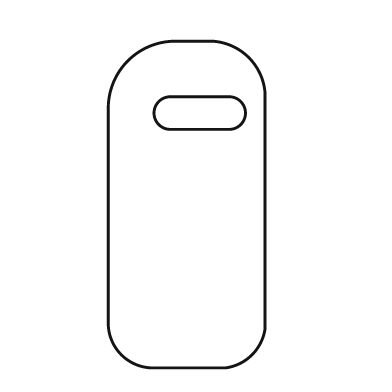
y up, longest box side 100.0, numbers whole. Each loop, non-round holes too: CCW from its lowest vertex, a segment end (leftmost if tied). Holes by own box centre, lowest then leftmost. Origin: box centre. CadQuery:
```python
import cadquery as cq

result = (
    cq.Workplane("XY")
    .moveTo(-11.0, -50.0)
    .lineTo(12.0, -50.0)
    .threePointArc((20.0, -46.0), (24.0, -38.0))
    .lineTo(24.0, 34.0)
    .threePointArc((19.0, 45.0), (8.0, 50.0))
    .lineTo(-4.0, 50.0)
    .threePointArc((-18.0, 44.0), (-24.0, 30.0))
    .lineTo(-24.0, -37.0)
    .threePointArc((-20.0, -46.0), (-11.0, -50.0))
    .close()
    .moveTo(-5.0, 23.0)
    .lineTo(13.0, 23.0)
    .threePointArc((18.0, 28.0), (13.0, 33.0))
    .lineTo(-5.0, 33.0)
    .threePointArc((-10.0, 28.0), (-5.0, 23.0))
    .close()
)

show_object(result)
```